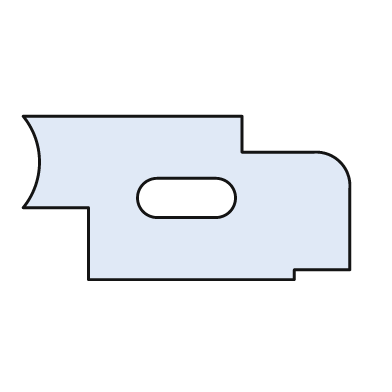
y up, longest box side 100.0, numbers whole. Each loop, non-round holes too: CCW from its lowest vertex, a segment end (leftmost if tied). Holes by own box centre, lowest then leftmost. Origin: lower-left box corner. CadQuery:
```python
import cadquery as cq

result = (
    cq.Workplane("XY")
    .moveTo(20.0, 0.0)
    .lineTo(83.0, 0.0)
    .lineTo(83.0, 3.0)
    .lineTo(100.0, 3.0)
    .lineTo(100.0, 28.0)
    .threePointArc((97.0, 36.0), (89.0, 39.0))
    .lineTo(67.0, 39.0)
    .lineTo(67.0, 50.0)
    .lineTo(0.0, 50.0)
    .threePointArc((5.0, 36.0), (0.0, 22.0))
    .lineTo(20.0, 22.0)
    .close()
    .moveTo(41.0, 19.0)
    .lineTo(59.0, 19.0)
    .threePointArc((65.0, 25.0), (59.0, 31.0))
    .lineTo(41.0, 31.0)
    .threePointArc((35.0, 25.0), (41.0, 19.0))
    .close()
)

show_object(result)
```